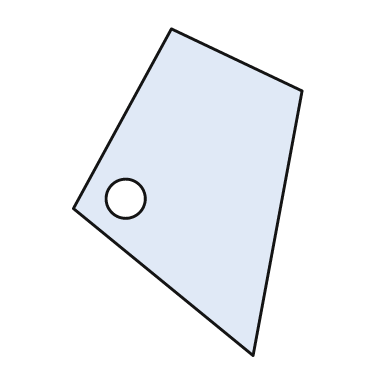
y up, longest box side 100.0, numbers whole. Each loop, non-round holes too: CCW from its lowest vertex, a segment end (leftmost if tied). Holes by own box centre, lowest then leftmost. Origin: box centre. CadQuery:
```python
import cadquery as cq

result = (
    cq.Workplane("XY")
    .moveTo(20.0, -50.0)
    .lineTo(35.0, 31.0)
    .lineTo(-5.0, 50.0)
    .lineTo(-35.0, -5.0)
    .close()
    .moveTo(-19.0, -2.0)
    .circle(6.0)
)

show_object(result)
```